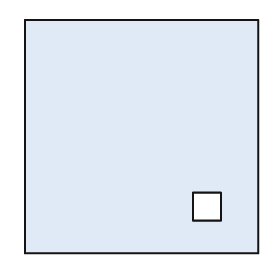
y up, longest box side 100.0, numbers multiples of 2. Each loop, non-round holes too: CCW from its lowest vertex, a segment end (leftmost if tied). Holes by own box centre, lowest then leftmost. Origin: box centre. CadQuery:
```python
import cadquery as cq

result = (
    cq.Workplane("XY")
    .moveTo(-50.0, -50.0)
    .lineTo(50.0, -50.0)
    .lineTo(50.0, 50.0)
    .lineTo(-50.0, 50.0)
    .close()
    .moveTo(22.0, -36.0)
    .lineTo(34.0, -36.0)
    .lineTo(34.0, -24.0)
    .lineTo(22.0, -24.0)
    .close()
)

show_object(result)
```